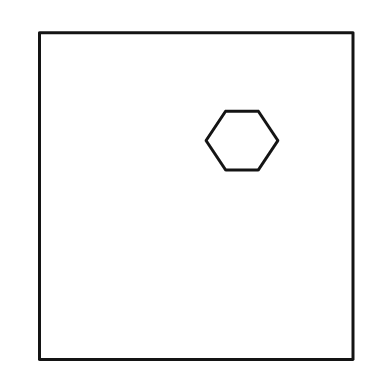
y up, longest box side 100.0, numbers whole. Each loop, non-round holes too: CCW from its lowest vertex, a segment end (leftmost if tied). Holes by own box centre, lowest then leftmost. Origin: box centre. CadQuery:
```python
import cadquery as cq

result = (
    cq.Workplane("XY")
    .moveTo(-48.0, -50.0)
    .lineTo(48.0, -50.0)
    .lineTo(48.0, 50.0)
    .lineTo(-48.0, 50.0)
    .close()
    .moveTo(9.0, 8.0)
    .lineTo(19.0, 8.0)
    .lineTo(25.0, 17.0)
    .lineTo(19.0, 26.0)
    .lineTo(9.0, 26.0)
    .lineTo(3.0, 17.0)
    .close()
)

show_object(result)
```